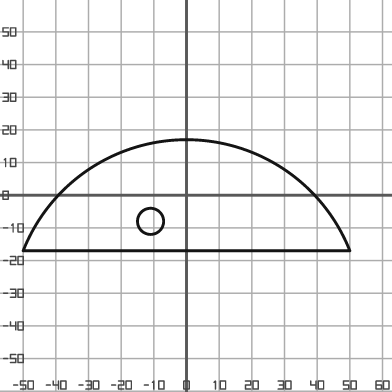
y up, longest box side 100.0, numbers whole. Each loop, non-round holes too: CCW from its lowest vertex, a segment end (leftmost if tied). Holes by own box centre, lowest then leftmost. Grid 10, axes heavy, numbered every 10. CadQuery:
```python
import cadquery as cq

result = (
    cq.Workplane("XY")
    .moveTo(-50.0, -17.0)
    .lineTo(50.0, -17.0)
    .threePointArc((0.0, 17.0), (-50.0, -17.0))
    .close()
    .moveTo(-11.0, -8.0)
    .circle(4.0)
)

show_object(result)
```